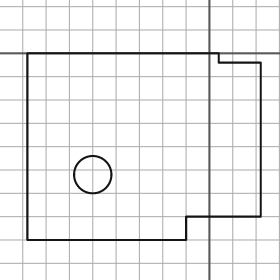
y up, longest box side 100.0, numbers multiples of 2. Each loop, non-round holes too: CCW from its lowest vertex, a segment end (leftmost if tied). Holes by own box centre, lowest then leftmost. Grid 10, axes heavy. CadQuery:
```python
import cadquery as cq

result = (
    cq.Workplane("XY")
    .moveTo(-78.0, -80.0)
    .lineTo(-10.0, -80.0)
    .lineTo(-10.0, -70.0)
    .lineTo(22.0, -70.0)
    .lineTo(22.0, -4.0)
    .lineTo(4.0, -4.0)
    .lineTo(4.0, 0.0)
    .lineTo(-78.0, 0.0)
    .close()
    .moveTo(-50.0, -52.0)
    .circle(8.0)
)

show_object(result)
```